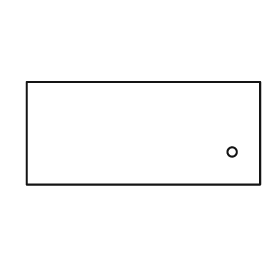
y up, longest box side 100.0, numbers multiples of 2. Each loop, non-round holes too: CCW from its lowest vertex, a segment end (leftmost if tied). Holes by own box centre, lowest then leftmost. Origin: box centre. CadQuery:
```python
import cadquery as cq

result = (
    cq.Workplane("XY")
    .moveTo(-50.0, -22.0)
    .lineTo(50.0, -22.0)
    .lineTo(50.0, 22.0)
    .lineTo(-50.0, 22.0)
    .close()
    .moveTo(38.0, -8.0)
    .circle(2.0)
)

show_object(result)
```